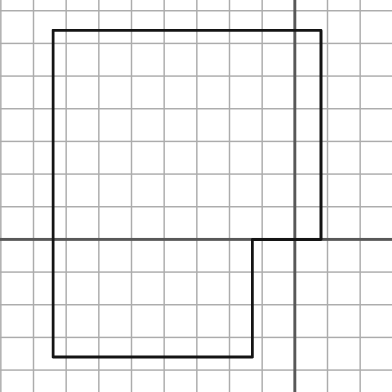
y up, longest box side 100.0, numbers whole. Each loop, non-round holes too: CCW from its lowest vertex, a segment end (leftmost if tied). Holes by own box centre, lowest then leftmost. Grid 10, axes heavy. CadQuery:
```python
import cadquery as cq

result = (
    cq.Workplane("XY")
    .moveTo(-74.0, -36.0)
    .lineTo(-13.0, -36.0)
    .lineTo(-13.0, 0.0)
    .lineTo(8.0, 0.0)
    .lineTo(8.0, 64.0)
    .lineTo(-74.0, 64.0)
    .close()
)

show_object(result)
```